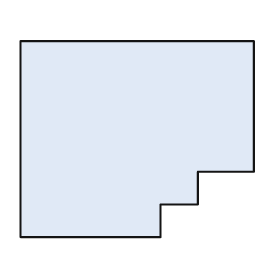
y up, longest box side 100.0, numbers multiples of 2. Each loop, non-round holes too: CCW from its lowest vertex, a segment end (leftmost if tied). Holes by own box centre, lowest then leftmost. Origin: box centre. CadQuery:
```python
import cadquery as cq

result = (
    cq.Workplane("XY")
    .moveTo(-50.0, -42.0)
    .lineTo(10.0, -42.0)
    .lineTo(10.0, -28.0)
    .lineTo(26.0, -28.0)
    .lineTo(26.0, -14.0)
    .lineTo(50.0, -14.0)
    .lineTo(50.0, 42.0)
    .lineTo(-50.0, 42.0)
    .close()
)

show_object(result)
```